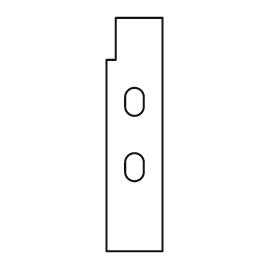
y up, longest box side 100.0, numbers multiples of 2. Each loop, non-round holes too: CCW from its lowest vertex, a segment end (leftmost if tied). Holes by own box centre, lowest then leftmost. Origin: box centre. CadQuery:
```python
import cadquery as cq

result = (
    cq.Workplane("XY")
    .moveTo(-12.0, -50.0)
    .lineTo(12.0, -50.0)
    .lineTo(12.0, 50.0)
    .lineTo(-8.0, 50.0)
    .lineTo(-8.0, 32.0)
    .lineTo(-12.0, 32.0)
    .close()
    .moveTo(-4.0, -16.0)
    .threePointArc((0.0, -20.0), (4.0, -16.0))
    .lineTo(4.0, -12.0)
    .threePointArc((0.0, -8.0), (-4.0, -12.0))
    .close()
    .moveTo(-4.0, 12.0)
    .threePointArc((0.0, 8.0), (4.0, 12.0))
    .lineTo(4.0, 16.0)
    .threePointArc((0.0, 20.0), (-4.0, 16.0))
    .close()
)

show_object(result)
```